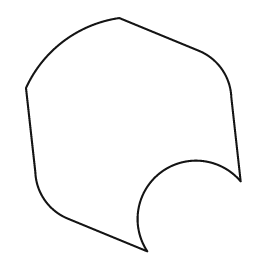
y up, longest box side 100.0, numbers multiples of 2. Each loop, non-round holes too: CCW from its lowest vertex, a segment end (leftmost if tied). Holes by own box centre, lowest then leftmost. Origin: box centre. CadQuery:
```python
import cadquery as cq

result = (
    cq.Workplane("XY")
    .moveTo(6.0, -50.0)
    .threePointArc((12.0, -16.0), (46.0, -20.0))
    .lineTo(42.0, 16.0)
    .threePointArc((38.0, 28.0), (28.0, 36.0))
    .lineTo(-6.0, 50.0)
    .threePointArc((-30.0, 40.0), (-46.0, 20.0))
    .lineTo(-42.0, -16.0)
    .threePointArc((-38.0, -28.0), (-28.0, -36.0))
    .close()
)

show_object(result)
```